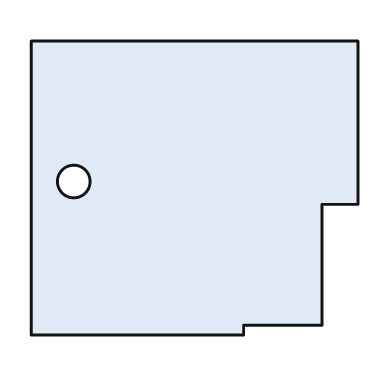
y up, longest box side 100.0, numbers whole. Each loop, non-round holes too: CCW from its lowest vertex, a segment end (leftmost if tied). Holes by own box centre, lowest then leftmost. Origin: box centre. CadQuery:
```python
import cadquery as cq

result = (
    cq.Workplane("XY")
    .moveTo(-50.0, -45.0)
    .lineTo(15.0, -45.0)
    .lineTo(15.0, -42.0)
    .lineTo(39.0, -42.0)
    .lineTo(39.0, -5.0)
    .lineTo(50.0, -5.0)
    .lineTo(50.0, 45.0)
    .lineTo(-50.0, 45.0)
    .close()
    .moveTo(-37.0, 2.0)
    .circle(5.0)
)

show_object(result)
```